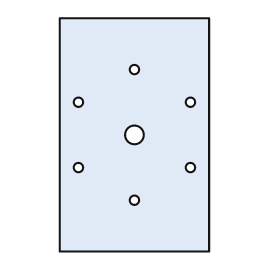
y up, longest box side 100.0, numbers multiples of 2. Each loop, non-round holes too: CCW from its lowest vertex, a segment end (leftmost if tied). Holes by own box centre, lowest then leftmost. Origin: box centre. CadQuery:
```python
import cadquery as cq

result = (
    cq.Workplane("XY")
    .moveTo(-32.0, -50.0)
    .lineTo(32.0, -50.0)
    .lineTo(32.0, 50.0)
    .lineTo(-32.0, 50.0)
    .close()
    .moveTo(0.0, -28.0)
    .circle(2.0)
    .moveTo(-24.0, -14.0)
    .circle(2.0)
    .moveTo(24.0, -14.0)
    .circle(2.0)
    .moveTo(0.0, 0.0)
    .circle(4.0)
    .moveTo(-24.0, 14.0)
    .circle(2.0)
    .moveTo(24.0, 14.0)
    .circle(2.0)
    .moveTo(0.0, 28.0)
    .circle(2.0)
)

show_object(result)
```